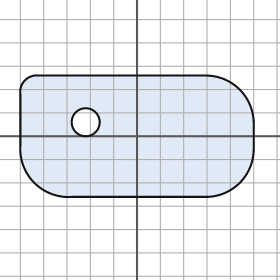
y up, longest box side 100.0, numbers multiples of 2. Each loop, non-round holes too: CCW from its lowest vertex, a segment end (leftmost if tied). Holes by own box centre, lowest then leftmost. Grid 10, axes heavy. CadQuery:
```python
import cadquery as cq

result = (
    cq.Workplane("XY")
    .moveTo(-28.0, -26.0)
    .lineTo(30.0, -26.0)
    .threePointArc((44.0, -20.0), (50.0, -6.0))
    .lineTo(50.0, 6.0)
    .threePointArc((44.0, 20.0), (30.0, 26.0))
    .lineTo(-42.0, 26.0)
    .threePointArc((-48.0, 24.0), (-50.0, 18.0))
    .lineTo(-50.0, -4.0)
    .threePointArc((-44.0, -20.0), (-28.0, -26.0))
    .close()
    .moveTo(-22.0, 6.0)
    .circle(6.0)
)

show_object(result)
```